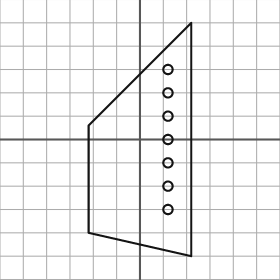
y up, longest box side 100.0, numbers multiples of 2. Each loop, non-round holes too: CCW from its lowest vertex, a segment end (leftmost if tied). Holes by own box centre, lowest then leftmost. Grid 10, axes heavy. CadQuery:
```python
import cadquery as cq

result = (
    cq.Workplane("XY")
    .moveTo(22.0, -50.0)
    .lineTo(22.0, 50.0)
    .lineTo(-22.0, 6.0)
    .lineTo(-22.0, -40.0)
    .close()
    .moveTo(12.0, -30.0)
    .circle(2.0)
    .moveTo(12.0, -20.0)
    .circle(2.0)
    .moveTo(12.0, -10.0)
    .circle(2.0)
    .moveTo(12.0, 0.0)
    .circle(2.0)
    .moveTo(12.0, 10.0)
    .circle(2.0)
    .moveTo(12.0, 20.0)
    .circle(2.0)
    .moveTo(12.0, 30.0)
    .circle(2.0)
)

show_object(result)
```